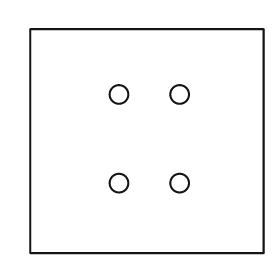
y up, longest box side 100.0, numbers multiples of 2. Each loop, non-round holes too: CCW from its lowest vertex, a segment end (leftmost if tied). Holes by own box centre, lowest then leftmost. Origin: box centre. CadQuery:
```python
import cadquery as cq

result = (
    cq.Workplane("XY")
    .moveTo(-50.0, -48.0)
    .lineTo(50.0, -48.0)
    .lineTo(50.0, 48.0)
    .lineTo(-50.0, 48.0)
    .close()
    .moveTo(-12.0, -18.0)
    .circle(4.0)
    .moveTo(14.0, -18.0)
    .circle(4.0)
    .moveTo(-12.0, 20.0)
    .circle(4.0)
    .moveTo(14.0, 20.0)
    .circle(4.0)
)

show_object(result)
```